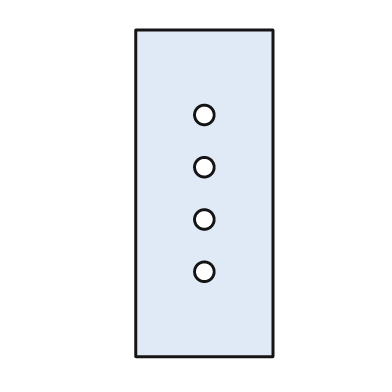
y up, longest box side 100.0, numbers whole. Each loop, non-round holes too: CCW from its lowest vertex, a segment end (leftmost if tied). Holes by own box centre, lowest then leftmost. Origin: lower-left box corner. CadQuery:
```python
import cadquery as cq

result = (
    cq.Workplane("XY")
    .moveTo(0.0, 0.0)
    .lineTo(42.0, 0.0)
    .lineTo(42.0, 100.0)
    .lineTo(0.0, 100.0)
    .close()
    .moveTo(21.0, 26.0)
    .circle(3.0)
    .moveTo(21.0, 42.0)
    .circle(3.0)
    .moveTo(21.0, 58.0)
    .circle(3.0)
    .moveTo(21.0, 74.0)
    .circle(3.0)
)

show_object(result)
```